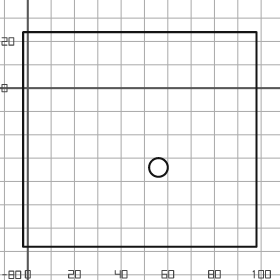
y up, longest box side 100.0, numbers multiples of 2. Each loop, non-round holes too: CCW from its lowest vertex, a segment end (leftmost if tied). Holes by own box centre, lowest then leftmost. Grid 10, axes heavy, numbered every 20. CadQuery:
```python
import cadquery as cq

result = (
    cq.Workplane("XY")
    .moveTo(-2.0, -68.0)
    .lineTo(98.0, -68.0)
    .lineTo(98.0, 24.0)
    .lineTo(-2.0, 24.0)
    .close()
    .moveTo(56.0, -34.0)
    .circle(4.0)
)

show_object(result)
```